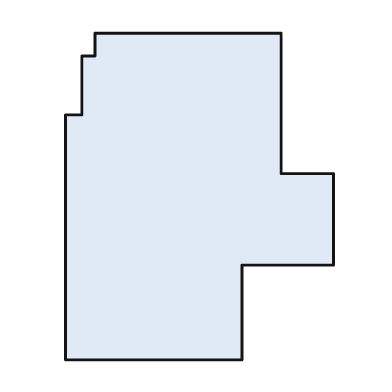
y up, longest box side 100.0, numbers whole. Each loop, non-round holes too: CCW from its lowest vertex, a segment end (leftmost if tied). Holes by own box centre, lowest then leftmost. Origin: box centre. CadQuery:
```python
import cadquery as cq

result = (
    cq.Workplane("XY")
    .moveTo(-41.0, -50.0)
    .lineTo(13.0, -50.0)
    .lineTo(13.0, -21.0)
    .lineTo(41.0, -21.0)
    .lineTo(41.0, 7.0)
    .lineTo(25.0, 7.0)
    .lineTo(25.0, 50.0)
    .lineTo(-32.0, 50.0)
    .lineTo(-32.0, 43.0)
    .lineTo(-36.0, 43.0)
    .lineTo(-36.0, 25.0)
    .lineTo(-41.0, 25.0)
    .close()
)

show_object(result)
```